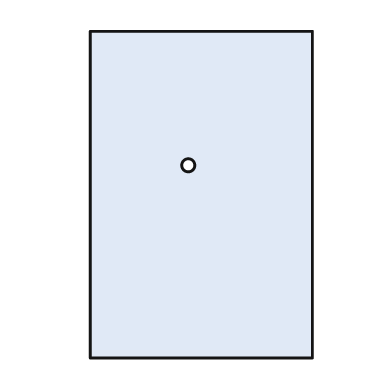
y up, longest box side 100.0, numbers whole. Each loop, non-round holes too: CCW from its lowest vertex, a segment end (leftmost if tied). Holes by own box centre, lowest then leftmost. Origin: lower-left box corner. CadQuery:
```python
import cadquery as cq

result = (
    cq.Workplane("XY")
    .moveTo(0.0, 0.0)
    .lineTo(68.0, 0.0)
    .lineTo(68.0, 100.0)
    .lineTo(0.0, 100.0)
    .close()
    .moveTo(30.0, 59.0)
    .circle(2.0)
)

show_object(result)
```